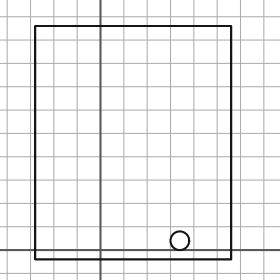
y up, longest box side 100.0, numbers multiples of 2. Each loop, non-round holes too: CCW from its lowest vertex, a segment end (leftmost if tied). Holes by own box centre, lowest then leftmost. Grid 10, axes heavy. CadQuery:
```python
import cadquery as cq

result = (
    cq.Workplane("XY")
    .moveTo(-28.0, -4.0)
    .lineTo(56.0, -4.0)
    .lineTo(56.0, 96.0)
    .lineTo(-28.0, 96.0)
    .close()
    .moveTo(34.0, 4.0)
    .circle(4.0)
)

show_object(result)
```